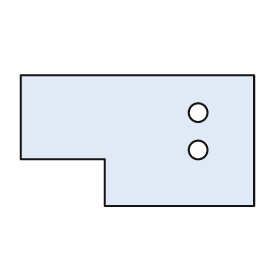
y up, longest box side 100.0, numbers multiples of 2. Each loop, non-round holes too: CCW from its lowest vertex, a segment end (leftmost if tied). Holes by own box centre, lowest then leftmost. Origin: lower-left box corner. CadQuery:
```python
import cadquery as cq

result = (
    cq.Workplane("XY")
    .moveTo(36.0, 0.0)
    .lineTo(100.0, 0.0)
    .lineTo(100.0, 56.0)
    .lineTo(0.0, 56.0)
    .lineTo(0.0, 20.0)
    .lineTo(36.0, 20.0)
    .close()
    .moveTo(76.0, 24.0)
    .circle(4.0)
    .moveTo(76.0, 40.0)
    .circle(4.0)
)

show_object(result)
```